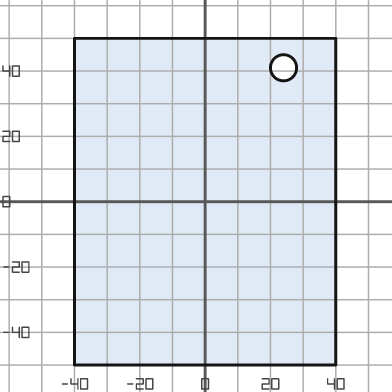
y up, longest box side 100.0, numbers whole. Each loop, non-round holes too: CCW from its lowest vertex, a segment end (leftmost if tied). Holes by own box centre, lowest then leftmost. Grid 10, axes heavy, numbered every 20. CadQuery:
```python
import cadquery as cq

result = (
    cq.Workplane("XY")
    .moveTo(-40.0, -50.0)
    .lineTo(40.0, -50.0)
    .lineTo(40.0, 50.0)
    .lineTo(-40.0, 50.0)
    .close()
    .moveTo(24.0, 41.0)
    .circle(4.0)
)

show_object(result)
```